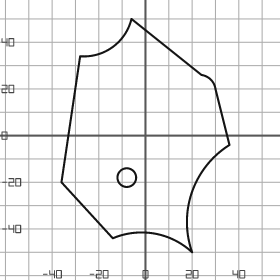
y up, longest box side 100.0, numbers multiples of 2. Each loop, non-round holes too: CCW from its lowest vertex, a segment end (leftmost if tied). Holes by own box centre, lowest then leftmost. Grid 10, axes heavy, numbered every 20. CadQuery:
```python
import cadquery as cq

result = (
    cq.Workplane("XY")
    .moveTo(20.0, -50.0)
    .threePointArc((20.0, -24.0), (36.0, -4.0))
    .lineTo(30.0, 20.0)
    .threePointArc((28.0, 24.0), (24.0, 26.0))
    .lineTo(-6.0, 50.0)
    .threePointArc((-14.0, 38.0), (-28.0, 34.0))
    .lineTo(-36.0, -20.0)
    .lineTo(-14.0, -44.0)
    .threePointArc((4.0, -42.0), (20.0, -50.0))
    .close()
    .moveTo(-8.0, -18.0)
    .circle(4.0)
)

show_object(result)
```